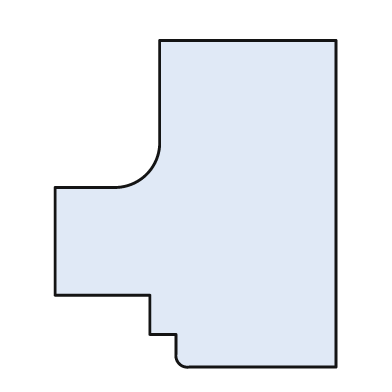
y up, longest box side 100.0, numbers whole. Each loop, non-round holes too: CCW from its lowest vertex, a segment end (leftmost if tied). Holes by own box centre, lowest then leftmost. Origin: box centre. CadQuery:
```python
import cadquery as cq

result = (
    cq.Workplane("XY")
    .moveTo(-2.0, -50.0)
    .lineTo(43.0, -50.0)
    .lineTo(43.0, 50.0)
    .lineTo(-11.0, 50.0)
    .lineTo(-11.0, 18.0)
    .threePointArc((-15.0, 9.0), (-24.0, 5.0))
    .lineTo(-43.0, 5.0)
    .lineTo(-43.0, -28.0)
    .lineTo(-14.0, -28.0)
    .lineTo(-14.0, -40.0)
    .lineTo(-6.0, -40.0)
    .lineTo(-6.0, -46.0)
    .threePointArc((-5.0, -49.0), (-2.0, -50.0))
    .close()
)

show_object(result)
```